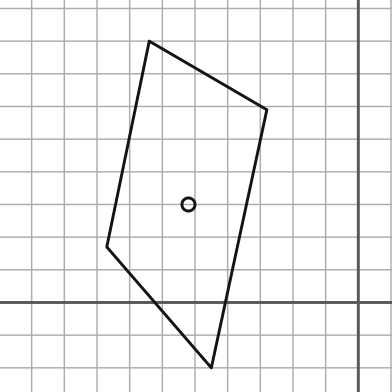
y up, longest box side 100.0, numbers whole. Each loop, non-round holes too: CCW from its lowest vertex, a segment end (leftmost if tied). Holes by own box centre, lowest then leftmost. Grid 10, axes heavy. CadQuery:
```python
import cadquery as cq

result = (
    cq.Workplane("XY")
    .moveTo(-45.0, -20.0)
    .lineTo(-28.0, 59.0)
    .lineTo(-64.0, 80.0)
    .lineTo(-77.0, 17.0)
    .close()
    .moveTo(-52.0, 30.0)
    .circle(2.0)
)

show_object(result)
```